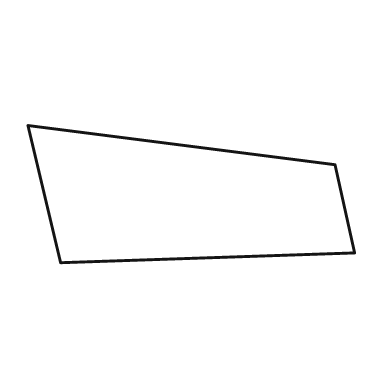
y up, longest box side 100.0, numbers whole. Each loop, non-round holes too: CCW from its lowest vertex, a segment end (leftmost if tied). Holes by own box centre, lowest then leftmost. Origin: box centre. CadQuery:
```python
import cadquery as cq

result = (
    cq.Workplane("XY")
    .moveTo(-40.0, -21.0)
    .lineTo(50.0, -18.0)
    .lineTo(44.0, 9.0)
    .lineTo(-50.0, 21.0)
    .close()
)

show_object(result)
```